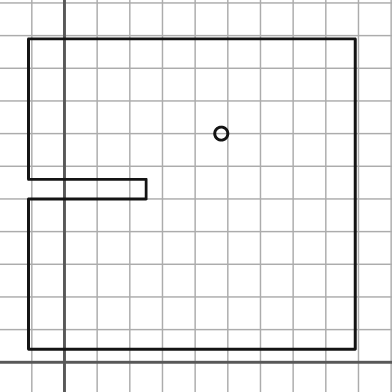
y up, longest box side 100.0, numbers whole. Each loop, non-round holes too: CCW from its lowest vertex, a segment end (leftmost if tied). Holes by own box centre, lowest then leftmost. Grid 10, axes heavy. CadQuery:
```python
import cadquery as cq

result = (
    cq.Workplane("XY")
    .moveTo(-11.0, 4.0)
    .lineTo(89.0, 4.0)
    .lineTo(89.0, 99.0)
    .lineTo(-11.0, 99.0)
    .lineTo(-11.0, 56.0)
    .lineTo(25.0, 56.0)
    .lineTo(25.0, 50.0)
    .lineTo(-11.0, 50.0)
    .close()
    .moveTo(48.0, 70.0)
    .circle(2.0)
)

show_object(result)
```